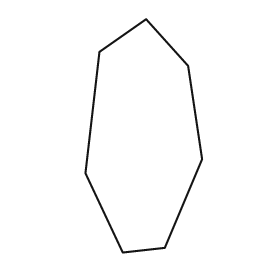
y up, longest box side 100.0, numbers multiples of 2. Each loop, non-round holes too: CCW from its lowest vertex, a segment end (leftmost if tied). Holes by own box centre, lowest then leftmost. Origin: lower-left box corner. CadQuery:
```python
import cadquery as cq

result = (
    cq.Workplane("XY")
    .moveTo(16.0, 0.0)
    .lineTo(34.0, 2.0)
    .lineTo(50.0, 40.0)
    .lineTo(44.0, 80.0)
    .lineTo(26.0, 100.0)
    .lineTo(6.0, 86.0)
    .lineTo(0.0, 34.0)
    .close()
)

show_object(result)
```